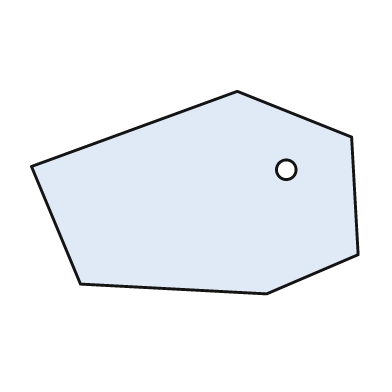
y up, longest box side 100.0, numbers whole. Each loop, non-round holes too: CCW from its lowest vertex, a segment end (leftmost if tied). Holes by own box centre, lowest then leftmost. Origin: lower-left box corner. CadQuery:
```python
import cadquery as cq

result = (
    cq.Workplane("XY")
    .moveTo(72.0, 0.0)
    .lineTo(100.0, 12.0)
    .lineTo(98.0, 48.0)
    .lineTo(63.0, 62.0)
    .lineTo(0.0, 39.0)
    .lineTo(15.0, 3.0)
    .close()
    .moveTo(78.0, 38.0)
    .circle(3.0)
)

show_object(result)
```